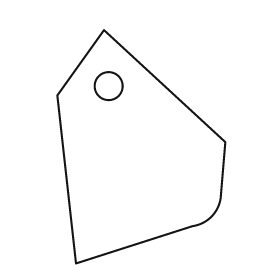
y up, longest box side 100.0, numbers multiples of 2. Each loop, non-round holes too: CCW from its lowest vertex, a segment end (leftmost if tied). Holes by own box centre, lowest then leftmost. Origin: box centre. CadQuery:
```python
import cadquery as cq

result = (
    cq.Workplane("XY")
    .moveTo(-28.0, -50.0)
    .lineTo(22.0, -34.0)
    .threePointArc((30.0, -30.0), (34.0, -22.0))
    .lineTo(36.0, 2.0)
    .lineTo(-16.0, 50.0)
    .lineTo(-36.0, 22.0)
    .close()
    .moveTo(-14.0, 26.0)
    .circle(6.0)
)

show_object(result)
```